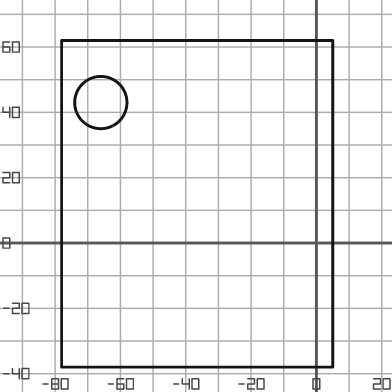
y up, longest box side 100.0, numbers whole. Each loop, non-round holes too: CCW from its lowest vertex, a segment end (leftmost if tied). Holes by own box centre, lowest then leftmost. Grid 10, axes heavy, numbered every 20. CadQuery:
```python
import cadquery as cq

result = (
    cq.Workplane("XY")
    .moveTo(-78.0, -38.0)
    .lineTo(5.0, -38.0)
    .lineTo(5.0, 62.0)
    .lineTo(-78.0, 62.0)
    .close()
    .moveTo(-66.0, 43.0)
    .circle(8.0)
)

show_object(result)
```